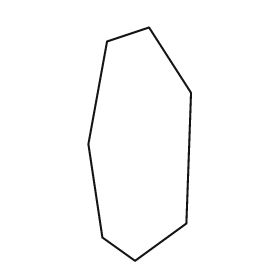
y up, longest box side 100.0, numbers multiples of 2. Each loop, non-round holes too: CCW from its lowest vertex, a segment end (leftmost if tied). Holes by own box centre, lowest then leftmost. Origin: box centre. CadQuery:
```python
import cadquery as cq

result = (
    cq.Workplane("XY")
    .moveTo(-2.0, -50.0)
    .lineTo(20.0, -34.0)
    .lineTo(22.0, 22.0)
    .lineTo(4.0, 50.0)
    .lineTo(-14.0, 44.0)
    .lineTo(-22.0, 0.0)
    .lineTo(-16.0, -40.0)
    .close()
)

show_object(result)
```